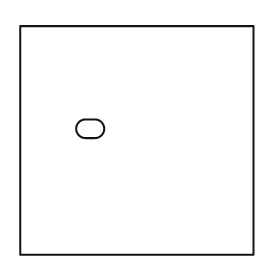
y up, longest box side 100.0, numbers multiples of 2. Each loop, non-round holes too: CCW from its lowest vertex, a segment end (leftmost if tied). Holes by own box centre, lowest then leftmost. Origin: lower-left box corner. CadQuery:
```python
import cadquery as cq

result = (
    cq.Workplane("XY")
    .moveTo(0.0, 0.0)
    .lineTo(100.0, 0.0)
    .lineTo(100.0, 98.0)
    .lineTo(0.0, 98.0)
    .close()
    .moveTo(28.0, 50.0)
    .lineTo(32.0, 50.0)
    .threePointArc((36.0, 54.0), (32.0, 58.0))
    .lineTo(28.0, 58.0)
    .threePointArc((24.0, 54.0), (28.0, 50.0))
    .close()
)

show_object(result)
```